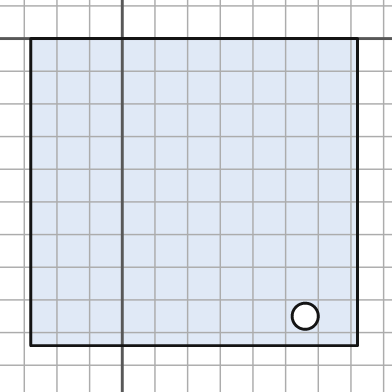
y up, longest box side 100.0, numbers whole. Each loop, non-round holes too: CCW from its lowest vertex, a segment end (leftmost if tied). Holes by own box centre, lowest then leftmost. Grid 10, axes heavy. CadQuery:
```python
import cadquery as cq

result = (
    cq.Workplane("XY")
    .moveTo(-28.0, -94.0)
    .lineTo(72.0, -94.0)
    .lineTo(72.0, 0.0)
    .lineTo(-28.0, 0.0)
    .close()
    .moveTo(56.0, -85.0)
    .circle(4.0)
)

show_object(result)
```